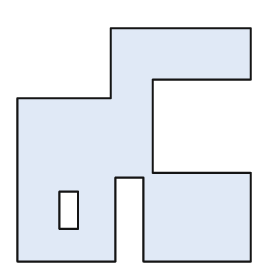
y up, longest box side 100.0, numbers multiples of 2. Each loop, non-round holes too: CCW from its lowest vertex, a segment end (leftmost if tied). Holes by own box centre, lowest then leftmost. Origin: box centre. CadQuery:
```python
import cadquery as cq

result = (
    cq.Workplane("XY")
    .moveTo(-50.0, -50.0)
    .lineTo(-8.0, -50.0)
    .lineTo(-8.0, -14.0)
    .lineTo(4.0, -14.0)
    .lineTo(4.0, -50.0)
    .lineTo(50.0, -50.0)
    .lineTo(50.0, -12.0)
    .lineTo(8.0, -12.0)
    .lineTo(8.0, 28.0)
    .lineTo(50.0, 28.0)
    .lineTo(50.0, 50.0)
    .lineTo(-10.0, 50.0)
    .lineTo(-10.0, 20.0)
    .lineTo(-50.0, 20.0)
    .close()
    .moveTo(-32.0, -36.0)
    .lineTo(-24.0, -36.0)
    .lineTo(-24.0, -20.0)
    .lineTo(-32.0, -20.0)
    .close()
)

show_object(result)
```